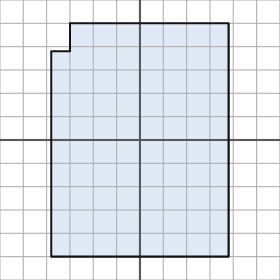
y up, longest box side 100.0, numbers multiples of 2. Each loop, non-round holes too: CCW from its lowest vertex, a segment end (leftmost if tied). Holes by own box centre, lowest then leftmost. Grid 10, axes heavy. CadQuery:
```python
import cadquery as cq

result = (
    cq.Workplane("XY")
    .moveTo(-38.0, -50.0)
    .lineTo(38.0, -50.0)
    .lineTo(38.0, 50.0)
    .lineTo(-30.0, 50.0)
    .lineTo(-30.0, 38.0)
    .lineTo(-38.0, 38.0)
    .close()
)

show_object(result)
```